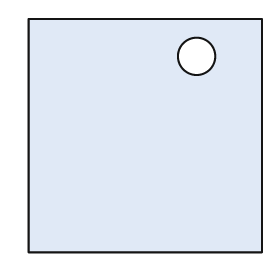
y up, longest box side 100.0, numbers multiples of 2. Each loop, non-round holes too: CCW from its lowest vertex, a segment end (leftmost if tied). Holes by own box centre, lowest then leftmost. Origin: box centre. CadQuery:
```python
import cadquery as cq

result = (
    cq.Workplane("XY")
    .moveTo(-50.0, -50.0)
    .lineTo(50.0, -50.0)
    .lineTo(50.0, 50.0)
    .lineTo(-50.0, 50.0)
    .close()
    .moveTo(22.0, 34.0)
    .circle(8.0)
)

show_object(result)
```